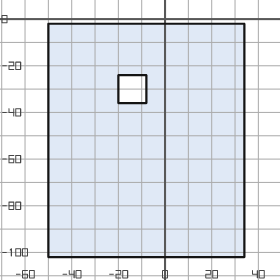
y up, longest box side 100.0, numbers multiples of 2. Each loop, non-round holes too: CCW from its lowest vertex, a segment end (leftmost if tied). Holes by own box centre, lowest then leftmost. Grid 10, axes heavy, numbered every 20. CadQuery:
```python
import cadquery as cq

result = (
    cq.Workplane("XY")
    .moveTo(-50.0, -102.0)
    .lineTo(34.0, -102.0)
    .lineTo(34.0, -2.0)
    .lineTo(-50.0, -2.0)
    .close()
    .moveTo(-20.0, -36.0)
    .lineTo(-8.0, -36.0)
    .lineTo(-8.0, -24.0)
    .lineTo(-20.0, -24.0)
    .close()
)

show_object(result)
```